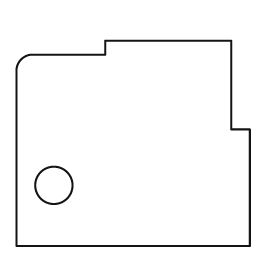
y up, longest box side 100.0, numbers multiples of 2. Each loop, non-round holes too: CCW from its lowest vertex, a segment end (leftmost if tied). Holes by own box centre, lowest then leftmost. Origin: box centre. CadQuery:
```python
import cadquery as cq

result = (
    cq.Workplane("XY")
    .moveTo(-50.0, -44.0)
    .lineTo(50.0, -44.0)
    .lineTo(50.0, 6.0)
    .lineTo(42.0, 6.0)
    .lineTo(42.0, 44.0)
    .lineTo(-12.0, 44.0)
    .lineTo(-12.0, 38.0)
    .lineTo(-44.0, 38.0)
    .threePointArc((-48.0, 36.0), (-50.0, 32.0))
    .close()
    .moveTo(-34.0, -18.0)
    .circle(8.0)
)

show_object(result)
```